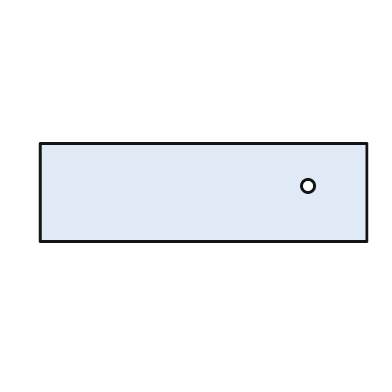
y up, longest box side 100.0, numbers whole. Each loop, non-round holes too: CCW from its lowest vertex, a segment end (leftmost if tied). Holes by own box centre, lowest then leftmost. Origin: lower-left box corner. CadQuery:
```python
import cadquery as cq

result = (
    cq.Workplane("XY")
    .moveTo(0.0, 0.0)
    .lineTo(100.0, 0.0)
    .lineTo(100.0, 30.0)
    .lineTo(0.0, 30.0)
    .close()
    .moveTo(82.0, 17.0)
    .circle(2.0)
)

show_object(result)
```